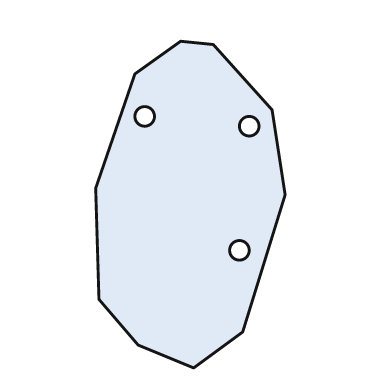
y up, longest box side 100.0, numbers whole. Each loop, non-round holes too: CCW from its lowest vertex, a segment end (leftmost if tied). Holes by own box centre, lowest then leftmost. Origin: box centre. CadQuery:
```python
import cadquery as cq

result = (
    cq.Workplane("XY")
    .moveTo(1.0, -50.0)
    .lineTo(16.0, -39.0)
    .lineTo(29.0, 3.0)
    .lineTo(25.0, 29.0)
    .lineTo(7.0, 49.0)
    .lineTo(-3.0, 50.0)
    .lineTo(-17.0, 40.0)
    .lineTo(-29.0, 5.0)
    .lineTo(-28.0, -29.0)
    .lineTo(-16.0, -43.0)
    .close()
    .moveTo(15.0, -14.0)
    .circle(3.0)
    .moveTo(18.0, 24.0)
    .circle(3.0)
    .moveTo(-14.0, 27.0)
    .circle(3.0)
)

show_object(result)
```